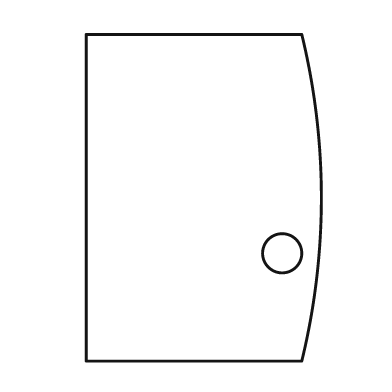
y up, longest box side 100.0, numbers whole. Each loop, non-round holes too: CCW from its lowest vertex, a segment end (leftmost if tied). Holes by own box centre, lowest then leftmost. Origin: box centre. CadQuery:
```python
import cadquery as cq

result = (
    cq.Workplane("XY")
    .moveTo(-36.0, -50.0)
    .lineTo(30.0, -50.0)
    .threePointArc((36.0, 0.0), (30.0, 50.0))
    .lineTo(-36.0, 50.0)
    .close()
    .moveTo(24.0, -17.0)
    .circle(6.0)
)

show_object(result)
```